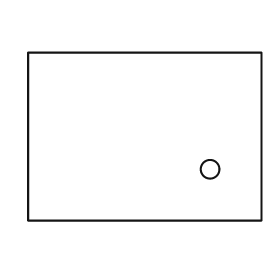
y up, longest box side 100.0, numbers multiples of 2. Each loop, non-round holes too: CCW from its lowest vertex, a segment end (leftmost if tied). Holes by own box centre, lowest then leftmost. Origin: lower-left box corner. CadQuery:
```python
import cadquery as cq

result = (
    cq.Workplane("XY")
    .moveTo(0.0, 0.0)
    .lineTo(100.0, 0.0)
    .lineTo(100.0, 72.0)
    .lineTo(0.0, 72.0)
    .close()
    .moveTo(78.0, 22.0)
    .circle(4.0)
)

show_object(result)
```